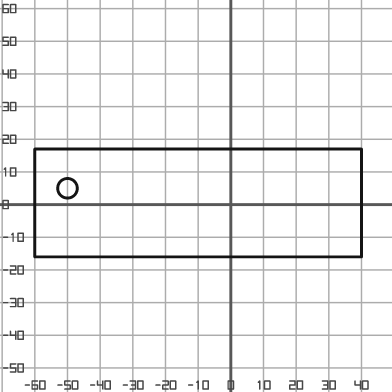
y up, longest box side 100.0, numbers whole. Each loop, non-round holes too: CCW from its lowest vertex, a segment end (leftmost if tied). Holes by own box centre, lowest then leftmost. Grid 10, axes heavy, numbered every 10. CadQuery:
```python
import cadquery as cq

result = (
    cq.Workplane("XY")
    .moveTo(-60.0, -16.0)
    .lineTo(40.0, -16.0)
    .lineTo(40.0, 17.0)
    .lineTo(-60.0, 17.0)
    .close()
    .moveTo(-50.0, 5.0)
    .circle(3.0)
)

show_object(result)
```